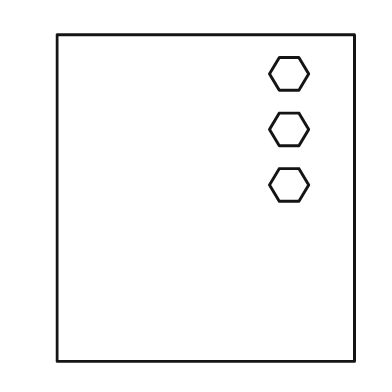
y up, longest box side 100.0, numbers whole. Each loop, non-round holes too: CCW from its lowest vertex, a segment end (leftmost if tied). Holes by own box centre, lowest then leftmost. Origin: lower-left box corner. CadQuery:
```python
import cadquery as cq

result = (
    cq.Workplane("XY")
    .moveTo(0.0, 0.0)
    .lineTo(91.0, 0.0)
    .lineTo(91.0, 100.0)
    .lineTo(0.0, 100.0)
    .close()
    .moveTo(68.0, 49.0)
    .lineTo(74.0, 49.0)
    .lineTo(77.0, 54.0)
    .lineTo(74.0, 59.0)
    .lineTo(68.0, 59.0)
    .lineTo(65.0, 54.0)
    .close()
    .moveTo(68.0, 66.0)
    .lineTo(74.0, 66.0)
    .lineTo(77.0, 71.0)
    .lineTo(74.0, 76.0)
    .lineTo(68.0, 76.0)
    .lineTo(65.0, 71.0)
    .close()
    .moveTo(68.0, 83.0)
    .lineTo(74.0, 83.0)
    .lineTo(77.0, 88.0)
    .lineTo(74.0, 93.0)
    .lineTo(68.0, 93.0)
    .lineTo(65.0, 88.0)
    .close()
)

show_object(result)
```